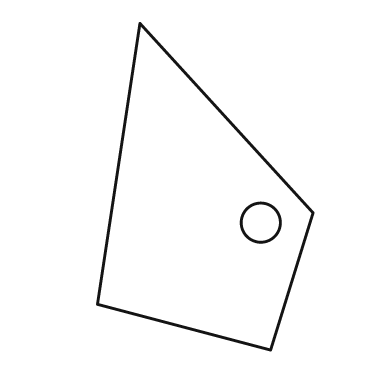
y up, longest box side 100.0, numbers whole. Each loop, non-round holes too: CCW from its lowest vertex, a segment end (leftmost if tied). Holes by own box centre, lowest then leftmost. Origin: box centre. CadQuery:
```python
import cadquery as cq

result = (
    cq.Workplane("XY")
    .moveTo(20.0, -50.0)
    .lineTo(33.0, -8.0)
    .lineTo(-20.0, 50.0)
    .lineTo(-33.0, -36.0)
    .close()
    .moveTo(17.0, -11.0)
    .circle(6.0)
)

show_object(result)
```